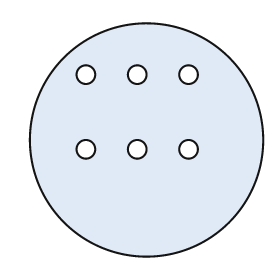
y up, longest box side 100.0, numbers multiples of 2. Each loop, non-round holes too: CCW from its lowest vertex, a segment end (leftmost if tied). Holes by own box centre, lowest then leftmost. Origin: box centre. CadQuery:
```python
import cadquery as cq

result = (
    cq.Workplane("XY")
    .moveTo(0.0, 0.0)
    .circle(50.0)
    .moveTo(-26.0, -4.0)
    .circle(4.0)
    .moveTo(-4.0, -4.0)
    .circle(4.0)
    .moveTo(18.0, -4.0)
    .circle(4.0)
    .moveTo(-26.0, 28.0)
    .circle(4.0)
    .moveTo(-4.0, 28.0)
    .circle(4.0)
    .moveTo(18.0, 28.0)
    .circle(4.0)
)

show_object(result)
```